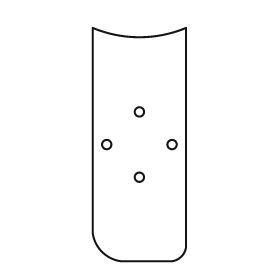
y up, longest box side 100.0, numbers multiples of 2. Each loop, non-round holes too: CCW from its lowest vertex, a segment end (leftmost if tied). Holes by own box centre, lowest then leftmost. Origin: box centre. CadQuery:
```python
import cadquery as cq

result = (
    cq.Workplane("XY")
    .moveTo(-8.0, -50.0)
    .lineTo(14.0, -50.0)
    .threePointArc((18.0, -48.0), (20.0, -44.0))
    .lineTo(20.0, 50.0)
    .threePointArc((0.0, 46.0), (-20.0, 50.0))
    .lineTo(-20.0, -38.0)
    .threePointArc((-16.0, -46.0), (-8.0, -50.0))
    .close()
    .moveTo(0.0, -14.0)
    .circle(2.0)
    .moveTo(-14.0, 0.0)
    .circle(2.0)
    .moveTo(14.0, 0.0)
    .circle(2.0)
    .moveTo(0.0, 14.0)
    .circle(2.0)
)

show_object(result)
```